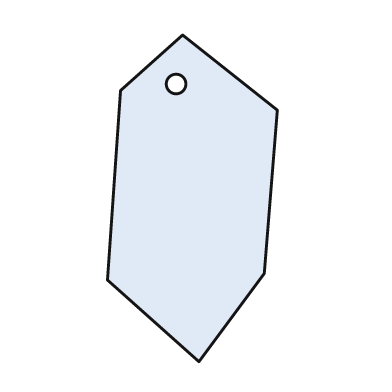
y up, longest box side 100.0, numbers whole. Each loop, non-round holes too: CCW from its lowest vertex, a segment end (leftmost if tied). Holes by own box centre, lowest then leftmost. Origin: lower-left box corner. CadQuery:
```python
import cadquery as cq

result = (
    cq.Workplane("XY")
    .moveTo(28.0, 0.0)
    .lineTo(48.0, 27.0)
    .lineTo(52.0, 77.0)
    .lineTo(23.0, 100.0)
    .lineTo(4.0, 83.0)
    .lineTo(0.0, 25.0)
    .close()
    .moveTo(21.0, 85.0)
    .circle(3.0)
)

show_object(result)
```